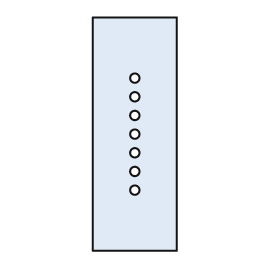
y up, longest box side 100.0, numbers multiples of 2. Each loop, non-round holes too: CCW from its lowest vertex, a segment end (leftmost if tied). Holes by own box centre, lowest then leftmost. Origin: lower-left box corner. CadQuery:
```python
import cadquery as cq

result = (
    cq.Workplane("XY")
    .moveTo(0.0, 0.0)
    .lineTo(36.0, 0.0)
    .lineTo(36.0, 100.0)
    .lineTo(0.0, 100.0)
    .close()
    .moveTo(18.0, 26.0)
    .circle(2.0)
    .moveTo(18.0, 34.0)
    .circle(2.0)
    .moveTo(18.0, 42.0)
    .circle(2.0)
    .moveTo(18.0, 50.0)
    .circle(2.0)
    .moveTo(18.0, 58.0)
    .circle(2.0)
    .moveTo(18.0, 66.0)
    .circle(2.0)
    .moveTo(18.0, 74.0)
    .circle(2.0)
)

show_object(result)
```